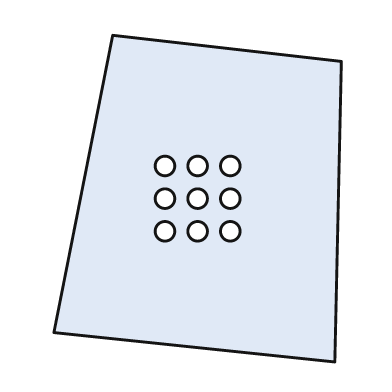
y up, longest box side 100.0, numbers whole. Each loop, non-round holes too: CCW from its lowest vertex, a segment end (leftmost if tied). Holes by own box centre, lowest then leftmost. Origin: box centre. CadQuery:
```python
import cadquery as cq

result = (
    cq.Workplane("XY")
    .moveTo(42.0, -50.0)
    .lineTo(44.0, 42.0)
    .lineTo(-26.0, 50.0)
    .lineTo(-44.0, -41.0)
    .close()
    .moveTo(-10.0, -10.0)
    .circle(3.0)
    .moveTo(0.0, -10.0)
    .circle(3.0)
    .moveTo(10.0, -10.0)
    .circle(3.0)
    .moveTo(-10.0, 0.0)
    .circle(3.0)
    .moveTo(0.0, 0.0)
    .circle(3.0)
    .moveTo(10.0, 0.0)
    .circle(3.0)
    .moveTo(-10.0, 10.0)
    .circle(3.0)
    .moveTo(0.0, 10.0)
    .circle(3.0)
    .moveTo(10.0, 10.0)
    .circle(3.0)
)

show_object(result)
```